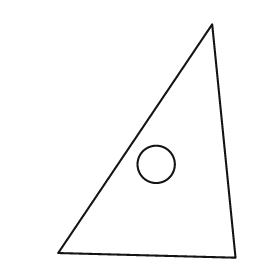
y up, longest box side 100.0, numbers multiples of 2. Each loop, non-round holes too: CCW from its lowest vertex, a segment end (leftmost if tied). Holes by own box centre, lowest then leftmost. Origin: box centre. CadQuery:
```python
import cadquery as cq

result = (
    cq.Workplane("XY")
    .moveTo(38.0, -50.0)
    .lineTo(28.0, 50.0)
    .lineTo(-38.0, -48.0)
    .close()
    .moveTo(4.0, -10.0)
    .circle(8.0)
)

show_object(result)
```